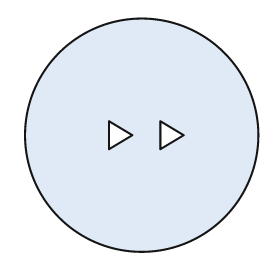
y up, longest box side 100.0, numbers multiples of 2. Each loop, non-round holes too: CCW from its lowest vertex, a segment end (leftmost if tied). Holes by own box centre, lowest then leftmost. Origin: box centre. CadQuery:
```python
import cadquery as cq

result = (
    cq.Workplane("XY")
    .moveTo(0.0, 0.0)
    .circle(50.0)
    .moveTo(-14.0, -6.0)
    .lineTo(-4.0, 0.0)
    .lineTo(-14.0, 6.0)
    .close()
    .moveTo(8.0, -6.0)
    .lineTo(18.0, 0.0)
    .lineTo(8.0, 6.0)
    .close()
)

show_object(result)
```